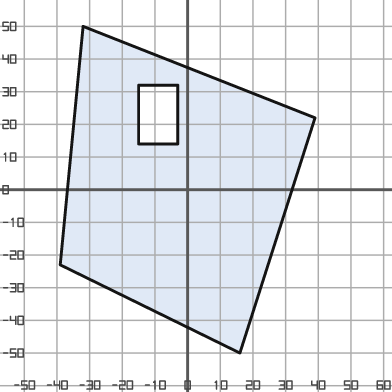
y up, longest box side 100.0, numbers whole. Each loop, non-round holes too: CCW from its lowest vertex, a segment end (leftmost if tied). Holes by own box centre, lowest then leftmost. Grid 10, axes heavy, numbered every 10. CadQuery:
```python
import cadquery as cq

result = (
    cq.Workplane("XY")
    .moveTo(16.0, -50.0)
    .lineTo(39.0, 22.0)
    .lineTo(-32.0, 50.0)
    .lineTo(-39.0, -23.0)
    .close()
    .moveTo(-15.0, 14.0)
    .lineTo(-3.0, 14.0)
    .lineTo(-3.0, 32.0)
    .lineTo(-15.0, 32.0)
    .close()
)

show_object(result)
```